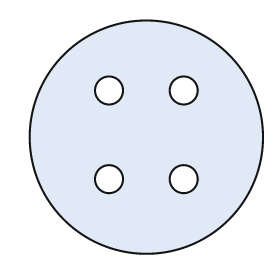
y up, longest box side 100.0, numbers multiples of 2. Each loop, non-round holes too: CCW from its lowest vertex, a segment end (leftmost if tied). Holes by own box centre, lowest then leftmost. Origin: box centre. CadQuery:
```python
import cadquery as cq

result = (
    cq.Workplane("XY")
    .moveTo(0.0, 0.0)
    .circle(50.0)
    .moveTo(-16.0, -18.0)
    .circle(6.0)
    .moveTo(16.0, -18.0)
    .circle(6.0)
    .moveTo(-16.0, 20.0)
    .circle(6.0)
    .moveTo(16.0, 20.0)
    .circle(6.0)
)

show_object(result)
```